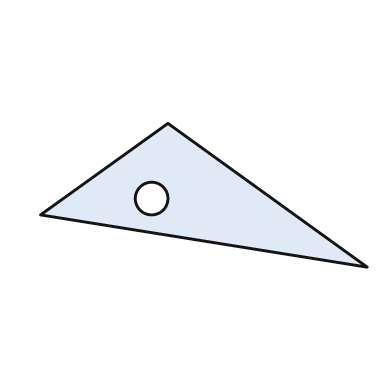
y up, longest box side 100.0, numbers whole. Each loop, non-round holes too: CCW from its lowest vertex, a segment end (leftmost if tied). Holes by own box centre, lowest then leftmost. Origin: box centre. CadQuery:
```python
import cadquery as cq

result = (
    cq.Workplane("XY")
    .moveTo(50.0, -22.0)
    .lineTo(-11.0, 22.0)
    .lineTo(-50.0, -6.0)
    .close()
    .moveTo(-16.0, -1.0)
    .circle(5.0)
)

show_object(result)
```